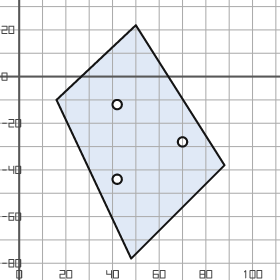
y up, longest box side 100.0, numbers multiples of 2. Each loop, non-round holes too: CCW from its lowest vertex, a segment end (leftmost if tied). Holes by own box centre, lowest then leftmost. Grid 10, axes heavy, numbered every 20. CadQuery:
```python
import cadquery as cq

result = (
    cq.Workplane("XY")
    .moveTo(48.0, -78.0)
    .lineTo(88.0, -38.0)
    .lineTo(50.0, 22.0)
    .lineTo(16.0, -10.0)
    .close()
    .moveTo(42.0, -44.0)
    .circle(2.0)
    .moveTo(70.0, -28.0)
    .circle(2.0)
    .moveTo(42.0, -12.0)
    .circle(2.0)
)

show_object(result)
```